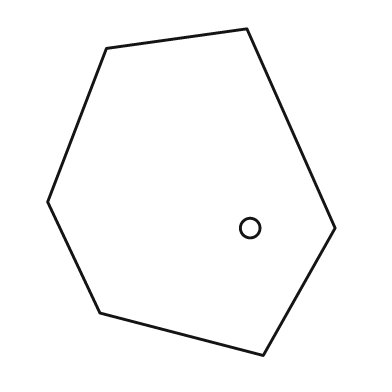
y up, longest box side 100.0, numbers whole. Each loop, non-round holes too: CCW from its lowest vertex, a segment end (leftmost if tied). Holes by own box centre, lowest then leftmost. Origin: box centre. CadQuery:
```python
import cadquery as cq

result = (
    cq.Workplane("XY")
    .moveTo(22.0, -50.0)
    .lineTo(44.0, -11.0)
    .lineTo(17.0, 50.0)
    .lineTo(-26.0, 44.0)
    .lineTo(-44.0, -3.0)
    .lineTo(-28.0, -37.0)
    .close()
    .moveTo(18.0, -11.0)
    .circle(3.0)
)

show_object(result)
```